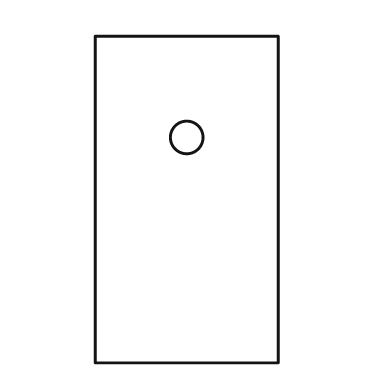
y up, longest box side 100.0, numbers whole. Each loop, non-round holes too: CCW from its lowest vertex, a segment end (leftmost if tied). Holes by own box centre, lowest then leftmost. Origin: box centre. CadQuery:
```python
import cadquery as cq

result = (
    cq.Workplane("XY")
    .moveTo(-28.0, -50.0)
    .lineTo(28.0, -50.0)
    .lineTo(28.0, 50.0)
    .lineTo(-28.0, 50.0)
    .close()
    .moveTo(0.0, 19.0)
    .circle(5.0)
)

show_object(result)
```